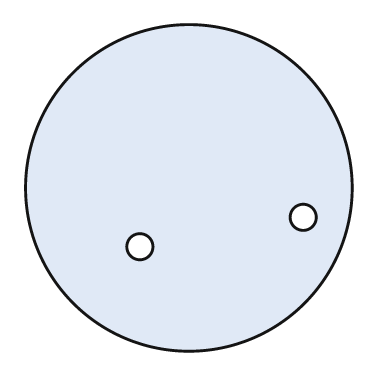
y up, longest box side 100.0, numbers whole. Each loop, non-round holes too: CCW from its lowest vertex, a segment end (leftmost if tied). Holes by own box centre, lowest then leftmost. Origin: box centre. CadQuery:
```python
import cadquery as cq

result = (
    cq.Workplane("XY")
    .moveTo(0.0, 0.0)
    .circle(50.0)
    .moveTo(-15.0, -18.0)
    .circle(4.0)
    .moveTo(35.0, -9.0)
    .circle(4.0)
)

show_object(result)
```